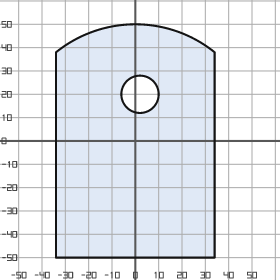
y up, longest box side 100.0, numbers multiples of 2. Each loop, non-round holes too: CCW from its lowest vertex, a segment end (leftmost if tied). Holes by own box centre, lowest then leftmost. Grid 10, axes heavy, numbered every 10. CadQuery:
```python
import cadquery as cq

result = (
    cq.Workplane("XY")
    .moveTo(-34.0, -50.0)
    .lineTo(34.0, -50.0)
    .lineTo(34.0, 38.0)
    .threePointArc((0.0, 50.0), (-34.0, 38.0))
    .close()
    .moveTo(2.0, 20.0)
    .circle(8.0)
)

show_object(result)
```